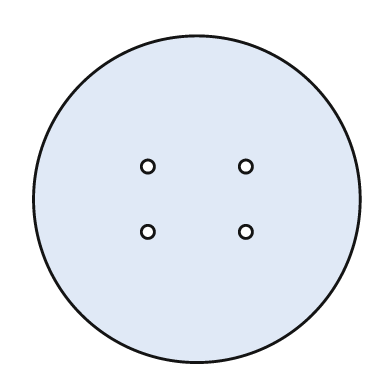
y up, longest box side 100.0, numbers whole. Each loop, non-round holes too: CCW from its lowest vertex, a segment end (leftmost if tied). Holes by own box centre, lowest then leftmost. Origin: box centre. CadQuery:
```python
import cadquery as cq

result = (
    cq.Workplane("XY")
    .moveTo(0.0, 0.0)
    .circle(50.0)
    .moveTo(-15.0, -10.0)
    .circle(2.0)
    .moveTo(15.0, -10.0)
    .circle(2.0)
    .moveTo(-15.0, 10.0)
    .circle(2.0)
    .moveTo(15.0, 10.0)
    .circle(2.0)
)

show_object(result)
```